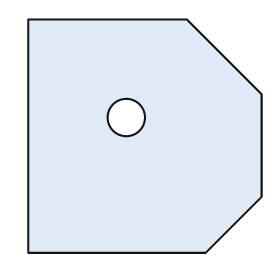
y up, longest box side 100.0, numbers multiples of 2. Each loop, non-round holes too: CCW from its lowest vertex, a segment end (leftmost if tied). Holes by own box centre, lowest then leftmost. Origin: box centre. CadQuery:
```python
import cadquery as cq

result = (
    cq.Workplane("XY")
    .moveTo(-50.0, -50.0)
    .lineTo(26.0, -50.0)
    .lineTo(50.0, -26.0)
    .lineTo(50.0, 18.0)
    .lineTo(18.0, 50.0)
    .lineTo(-50.0, 50.0)
    .close()
    .moveTo(-8.0, 8.0)
    .circle(8.0)
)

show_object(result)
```